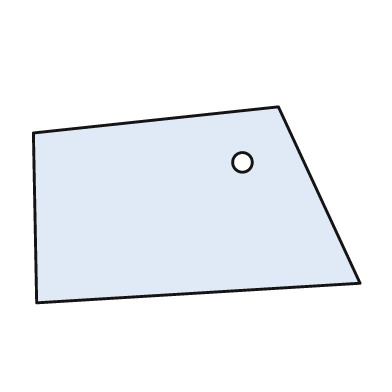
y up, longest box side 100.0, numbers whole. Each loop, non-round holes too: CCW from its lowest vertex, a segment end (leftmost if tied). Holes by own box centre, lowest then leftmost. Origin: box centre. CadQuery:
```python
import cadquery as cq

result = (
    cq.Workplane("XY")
    .moveTo(-49.0, -30.0)
    .lineTo(50.0, -24.0)
    .lineTo(25.0, 30.0)
    .lineTo(-50.0, 22.0)
    .close()
    .moveTo(14.0, 13.0)
    .circle(3.0)
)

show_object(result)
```